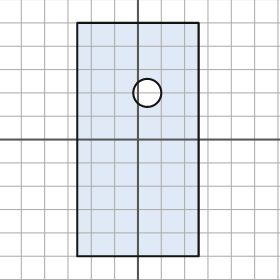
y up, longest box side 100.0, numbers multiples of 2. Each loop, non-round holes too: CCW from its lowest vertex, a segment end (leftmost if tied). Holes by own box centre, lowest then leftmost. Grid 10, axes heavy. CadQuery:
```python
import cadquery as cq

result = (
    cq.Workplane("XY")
    .moveTo(-26.0, -50.0)
    .lineTo(26.0, -50.0)
    .lineTo(26.0, 50.0)
    .lineTo(-26.0, 50.0)
    .close()
    .moveTo(4.0, 20.0)
    .circle(6.0)
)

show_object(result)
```